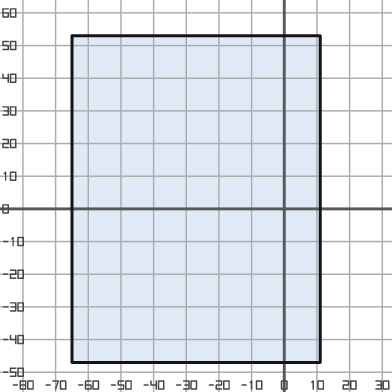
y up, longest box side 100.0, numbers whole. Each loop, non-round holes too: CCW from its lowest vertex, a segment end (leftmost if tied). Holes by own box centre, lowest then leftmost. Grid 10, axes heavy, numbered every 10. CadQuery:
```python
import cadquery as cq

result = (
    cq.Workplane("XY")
    .moveTo(-65.0, -47.0)
    .lineTo(11.0, -47.0)
    .lineTo(11.0, 53.0)
    .lineTo(-65.0, 53.0)
    .close()
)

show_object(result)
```